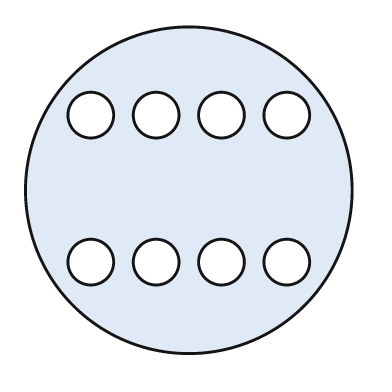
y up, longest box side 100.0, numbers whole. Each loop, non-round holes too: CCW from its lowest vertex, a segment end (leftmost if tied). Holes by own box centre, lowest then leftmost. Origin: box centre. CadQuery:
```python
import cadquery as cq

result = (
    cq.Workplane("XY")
    .moveTo(0.0, 0.0)
    .circle(50.0)
    .moveTo(-30.0, -22.0)
    .circle(7.0)
    .moveTo(-10.0, -22.0)
    .circle(7.0)
    .moveTo(10.0, -22.0)
    .circle(7.0)
    .moveTo(30.0, -22.0)
    .circle(7.0)
    .moveTo(-30.0, 23.0)
    .circle(7.0)
    .moveTo(-10.0, 23.0)
    .circle(7.0)
    .moveTo(10.0, 23.0)
    .circle(7.0)
    .moveTo(30.0, 23.0)
    .circle(7.0)
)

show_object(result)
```